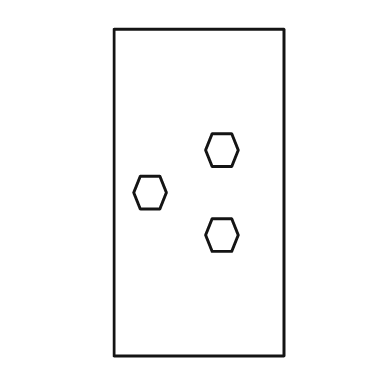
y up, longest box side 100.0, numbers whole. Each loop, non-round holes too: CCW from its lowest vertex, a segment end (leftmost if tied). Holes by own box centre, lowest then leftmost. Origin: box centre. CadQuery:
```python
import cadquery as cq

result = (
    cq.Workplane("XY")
    .moveTo(-26.0, -50.0)
    .lineTo(26.0, -50.0)
    .lineTo(26.0, 50.0)
    .lineTo(-26.0, 50.0)
    .close()
    .moveTo(4.0, -18.0)
    .lineTo(10.0, -18.0)
    .lineTo(12.0, -13.0)
    .lineTo(10.0, -8.0)
    .lineTo(4.0, -8.0)
    .lineTo(2.0, -13.0)
    .close()
    .moveTo(-18.0, -5.0)
    .lineTo(-12.0, -5.0)
    .lineTo(-10.0, 0.0)
    .lineTo(-12.0, 5.0)
    .lineTo(-18.0, 5.0)
    .lineTo(-20.0, 0.0)
    .close()
    .moveTo(4.0, 8.0)
    .lineTo(10.0, 8.0)
    .lineTo(12.0, 13.0)
    .lineTo(10.0, 18.0)
    .lineTo(4.0, 18.0)
    .lineTo(2.0, 13.0)
    .close()
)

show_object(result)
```